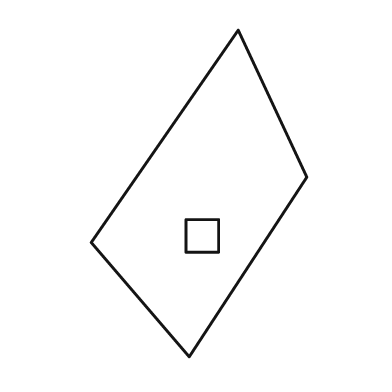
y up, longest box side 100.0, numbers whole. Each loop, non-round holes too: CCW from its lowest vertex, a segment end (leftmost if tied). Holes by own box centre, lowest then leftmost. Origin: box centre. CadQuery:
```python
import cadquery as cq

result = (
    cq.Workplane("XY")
    .moveTo(-3.0, -50.0)
    .lineTo(33.0, 5.0)
    .lineTo(12.0, 50.0)
    .lineTo(-33.0, -15.0)
    .close()
    .moveTo(-4.0, -18.0)
    .lineTo(6.0, -18.0)
    .lineTo(6.0, -8.0)
    .lineTo(-4.0, -8.0)
    .close()
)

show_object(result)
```